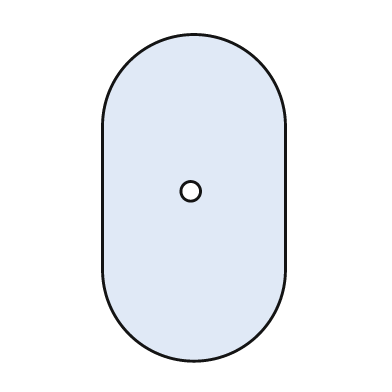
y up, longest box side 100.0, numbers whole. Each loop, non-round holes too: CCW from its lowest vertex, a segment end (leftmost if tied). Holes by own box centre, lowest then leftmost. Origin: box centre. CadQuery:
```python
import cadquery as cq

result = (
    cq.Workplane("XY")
    .moveTo(-28.0, -22.0)
    .threePointArc((0.0, -50.0), (28.0, -22.0))
    .lineTo(28.0, 22.0)
    .threePointArc((0.0, 50.0), (-28.0, 22.0))
    .close()
    .moveTo(-1.0, 2.0)
    .circle(3.0)
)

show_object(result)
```